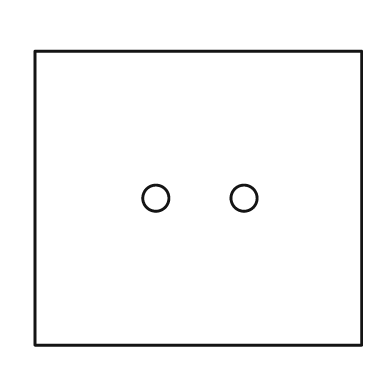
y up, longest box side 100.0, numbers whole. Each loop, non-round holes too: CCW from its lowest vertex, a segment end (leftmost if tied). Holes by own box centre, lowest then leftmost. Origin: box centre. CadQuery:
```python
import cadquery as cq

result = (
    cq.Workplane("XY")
    .moveTo(-50.0, -45.0)
    .lineTo(50.0, -45.0)
    .lineTo(50.0, 45.0)
    .lineTo(-50.0, 45.0)
    .close()
    .moveTo(-13.0, 0.0)
    .circle(4.0)
    .moveTo(14.0, 0.0)
    .circle(4.0)
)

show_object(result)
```